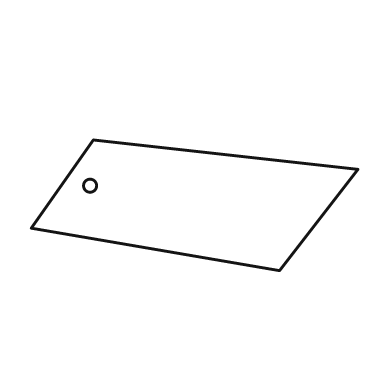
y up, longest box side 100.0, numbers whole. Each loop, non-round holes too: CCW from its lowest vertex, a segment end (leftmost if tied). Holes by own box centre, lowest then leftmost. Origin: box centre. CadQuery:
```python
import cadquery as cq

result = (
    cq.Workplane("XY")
    .moveTo(26.0, -20.0)
    .lineTo(50.0, 11.0)
    .lineTo(-31.0, 20.0)
    .lineTo(-50.0, -7.0)
    .close()
    .moveTo(-32.0, 6.0)
    .circle(2.0)
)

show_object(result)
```